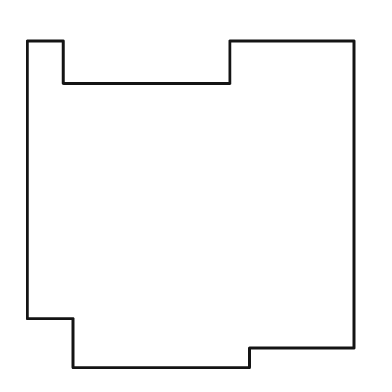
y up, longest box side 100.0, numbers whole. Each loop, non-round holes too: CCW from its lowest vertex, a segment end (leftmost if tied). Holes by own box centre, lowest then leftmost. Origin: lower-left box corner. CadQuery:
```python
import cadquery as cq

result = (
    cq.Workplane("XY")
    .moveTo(14.0, 0.0)
    .lineTo(68.0, 0.0)
    .lineTo(68.0, 6.0)
    .lineTo(100.0, 6.0)
    .lineTo(100.0, 100.0)
    .lineTo(62.0, 100.0)
    .lineTo(62.0, 87.0)
    .lineTo(11.0, 87.0)
    .lineTo(11.0, 100.0)
    .lineTo(0.0, 100.0)
    .lineTo(0.0, 15.0)
    .lineTo(14.0, 15.0)
    .close()
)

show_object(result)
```